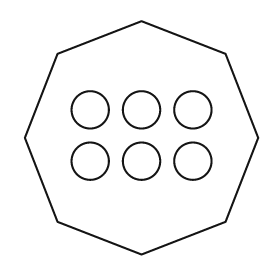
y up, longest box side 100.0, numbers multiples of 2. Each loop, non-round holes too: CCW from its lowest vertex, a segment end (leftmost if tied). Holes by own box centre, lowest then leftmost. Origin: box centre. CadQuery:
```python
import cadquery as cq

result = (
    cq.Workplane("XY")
    .moveTo(0.0, -50.0)
    .lineTo(36.0, -36.0)
    .lineTo(50.0, 0.0)
    .lineTo(36.0, 36.0)
    .lineTo(0.0, 50.0)
    .lineTo(-36.0, 36.0)
    .lineTo(-50.0, 0.0)
    .lineTo(-36.0, -36.0)
    .close()
    .moveTo(-22.0, -10.0)
    .circle(8.0)
    .moveTo(0.0, -10.0)
    .circle(8.0)
    .moveTo(22.0, -10.0)
    .circle(8.0)
    .moveTo(-22.0, 12.0)
    .circle(8.0)
    .moveTo(0.0, 12.0)
    .circle(8.0)
    .moveTo(22.0, 12.0)
    .circle(8.0)
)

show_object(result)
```